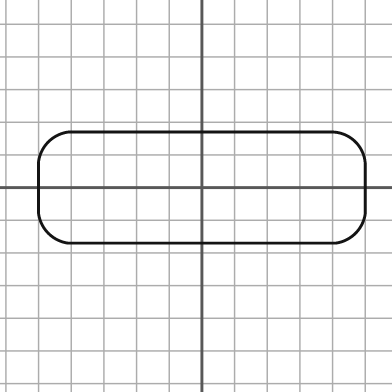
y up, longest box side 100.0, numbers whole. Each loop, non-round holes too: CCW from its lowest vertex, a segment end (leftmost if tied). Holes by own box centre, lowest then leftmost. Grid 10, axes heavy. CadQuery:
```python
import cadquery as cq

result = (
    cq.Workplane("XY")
    .moveTo(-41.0, -17.0)
    .lineTo(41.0, -17.0)
    .threePointArc((47.0, -14.0), (50.0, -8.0))
    .lineTo(50.0, 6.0)
    .threePointArc((47.0, 14.0), (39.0, 17.0))
    .lineTo(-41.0, 17.0)
    .threePointArc((-47.0, 14.0), (-50.0, 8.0))
    .lineTo(-50.0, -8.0)
    .threePointArc((-47.0, -14.0), (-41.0, -17.0))
    .close()
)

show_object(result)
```